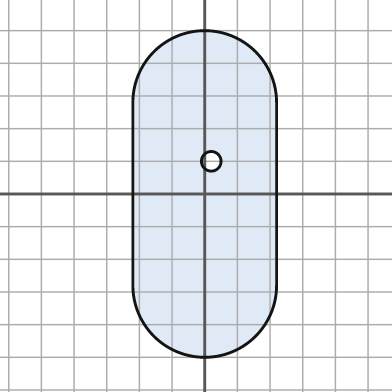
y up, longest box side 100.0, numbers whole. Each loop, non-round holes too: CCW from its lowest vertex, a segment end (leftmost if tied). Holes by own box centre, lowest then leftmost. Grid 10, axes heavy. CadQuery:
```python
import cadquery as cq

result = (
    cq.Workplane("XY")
    .moveTo(-22.0, -28.0)
    .threePointArc((0.0, -50.0), (22.0, -28.0))
    .lineTo(22.0, 28.0)
    .threePointArc((0.0, 50.0), (-22.0, 28.0))
    .close()
    .moveTo(2.0, 10.0)
    .circle(3.0)
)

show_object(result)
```